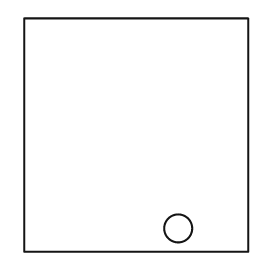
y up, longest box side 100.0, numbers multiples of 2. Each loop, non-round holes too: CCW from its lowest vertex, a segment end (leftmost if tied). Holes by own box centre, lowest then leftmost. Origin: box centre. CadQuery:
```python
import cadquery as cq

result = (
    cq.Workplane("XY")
    .moveTo(-48.0, -50.0)
    .lineTo(48.0, -50.0)
    .lineTo(48.0, 50.0)
    .lineTo(-48.0, 50.0)
    .close()
    .moveTo(18.0, -40.0)
    .circle(6.0)
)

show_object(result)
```